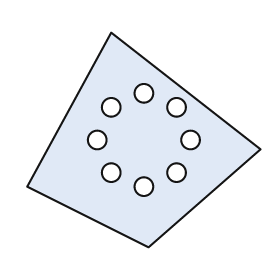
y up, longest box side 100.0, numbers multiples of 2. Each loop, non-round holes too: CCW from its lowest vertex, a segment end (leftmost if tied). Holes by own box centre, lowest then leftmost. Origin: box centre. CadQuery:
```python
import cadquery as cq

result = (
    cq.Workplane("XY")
    .moveTo(2.0, -46.0)
    .lineTo(50.0, -4.0)
    .lineTo(-14.0, 46.0)
    .lineTo(-50.0, -20.0)
    .close()
    .moveTo(0.0, -20.0)
    .circle(4.0)
    .moveTo(-14.0, -14.0)
    .circle(4.0)
    .moveTo(14.0, -14.0)
    .circle(4.0)
    .moveTo(-20.0, 0.0)
    .circle(4.0)
    .moveTo(20.0, 0.0)
    .circle(4.0)
    .moveTo(-14.0, 14.0)
    .circle(4.0)
    .moveTo(14.0, 14.0)
    .circle(4.0)
    .moveTo(0.0, 20.0)
    .circle(4.0)
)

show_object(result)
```